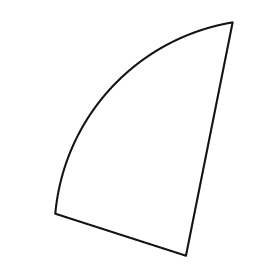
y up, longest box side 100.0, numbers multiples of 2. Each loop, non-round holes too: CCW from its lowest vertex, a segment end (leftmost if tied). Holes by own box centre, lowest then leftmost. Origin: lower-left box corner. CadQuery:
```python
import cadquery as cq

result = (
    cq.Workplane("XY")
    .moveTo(56.0, 0.0)
    .lineTo(76.0, 100.0)
    .threePointArc((24.0, 72.0), (0.0, 18.0))
    .close()
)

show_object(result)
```